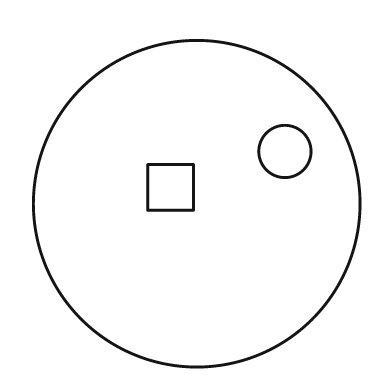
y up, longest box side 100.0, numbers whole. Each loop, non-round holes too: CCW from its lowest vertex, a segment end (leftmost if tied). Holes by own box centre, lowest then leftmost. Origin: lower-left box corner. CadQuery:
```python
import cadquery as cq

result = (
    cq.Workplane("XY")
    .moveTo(50.0, 50.0)
    .circle(50.0)
    .moveTo(35.0, 48.0)
    .lineTo(49.0, 48.0)
    .lineTo(49.0, 62.0)
    .lineTo(35.0, 62.0)
    .close()
    .moveTo(77.0, 66.0)
    .circle(8.0)
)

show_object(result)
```